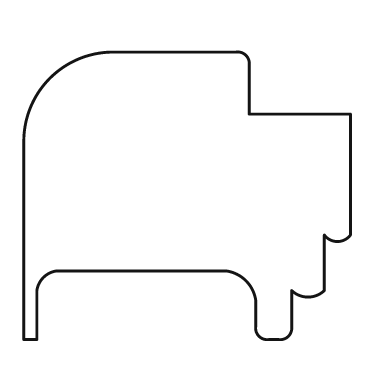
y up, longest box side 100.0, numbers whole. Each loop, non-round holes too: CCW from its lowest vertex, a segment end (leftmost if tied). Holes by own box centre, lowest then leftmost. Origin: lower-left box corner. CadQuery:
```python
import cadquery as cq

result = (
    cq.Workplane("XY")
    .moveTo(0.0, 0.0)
    .lineTo(4.0, 0.0)
    .lineTo(4.0, 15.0)
    .threePointArc((6.0, 19.0), (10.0, 21.0))
    .lineTo(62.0, 21.0)
    .threePointArc((68.0, 18.0), (71.0, 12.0))
    .lineTo(71.0, 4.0)
    .threePointArc((72.0, 1.0), (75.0, 0.0))
    .lineTo(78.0, 0.0)
    .threePointArc((81.0, 1.0), (82.0, 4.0))
    .lineTo(82.0, 15.0)
    .threePointArc((87.0, 13.0), (92.0, 15.0))
    .lineTo(92.0, 32.0)
    .threePointArc((96.0, 30.0), (100.0, 32.0))
    .lineTo(100.0, 69.0)
    .lineTo(69.0, 69.0)
    .lineTo(69.0, 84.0)
    .threePointArc((68.0, 87.0), (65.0, 88.0))
    .lineTo(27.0, 88.0)
    .threePointArc((8.0, 80.0), (0.0, 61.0))
    .close()
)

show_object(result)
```